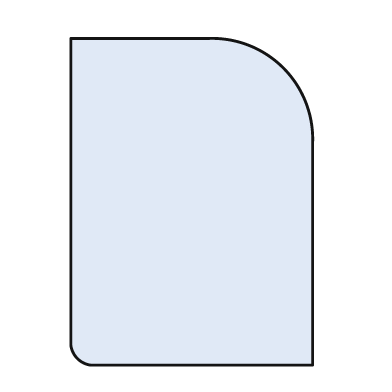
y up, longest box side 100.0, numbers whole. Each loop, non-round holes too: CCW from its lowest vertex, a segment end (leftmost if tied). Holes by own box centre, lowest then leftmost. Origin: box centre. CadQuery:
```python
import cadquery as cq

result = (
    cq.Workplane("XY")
    .moveTo(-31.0, -50.0)
    .lineTo(37.0, -50.0)
    .lineTo(37.0, 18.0)
    .threePointArc((28.0, 41.0), (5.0, 50.0))
    .lineTo(-37.0, 50.0)
    .lineTo(-37.0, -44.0)
    .threePointArc((-35.0, -48.0), (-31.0, -50.0))
    .close()
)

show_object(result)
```